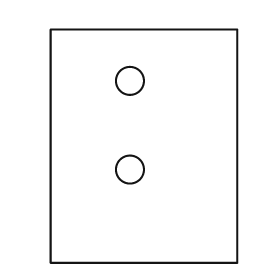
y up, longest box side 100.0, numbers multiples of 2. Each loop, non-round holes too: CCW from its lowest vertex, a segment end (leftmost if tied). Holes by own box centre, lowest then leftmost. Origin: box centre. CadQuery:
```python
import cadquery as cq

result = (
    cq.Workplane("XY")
    .moveTo(-40.0, -50.0)
    .lineTo(40.0, -50.0)
    .lineTo(40.0, 50.0)
    .lineTo(-40.0, 50.0)
    .close()
    .moveTo(-6.0, -10.0)
    .circle(6.0)
    .moveTo(-6.0, 28.0)
    .circle(6.0)
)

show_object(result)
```